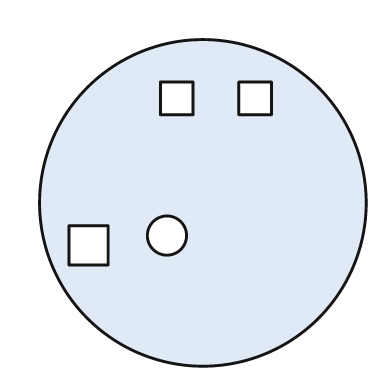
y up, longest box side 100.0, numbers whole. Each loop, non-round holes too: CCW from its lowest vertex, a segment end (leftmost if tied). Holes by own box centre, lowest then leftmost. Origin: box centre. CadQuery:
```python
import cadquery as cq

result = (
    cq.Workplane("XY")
    .moveTo(0.0, 0.0)
    .circle(50.0)
    .moveTo(-41.0, -19.0)
    .lineTo(-29.0, -19.0)
    .lineTo(-29.0, -7.0)
    .lineTo(-41.0, -7.0)
    .close()
    .moveTo(-11.0, -10.0)
    .circle(6.0)
    .moveTo(-13.0, 27.0)
    .lineTo(-3.0, 27.0)
    .lineTo(-3.0, 37.0)
    .lineTo(-13.0, 37.0)
    .close()
    .moveTo(11.0, 27.0)
    .lineTo(21.0, 27.0)
    .lineTo(21.0, 37.0)
    .lineTo(11.0, 37.0)
    .close()
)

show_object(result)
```